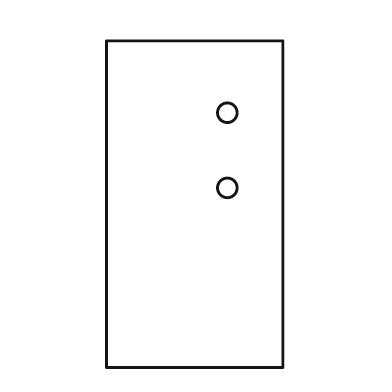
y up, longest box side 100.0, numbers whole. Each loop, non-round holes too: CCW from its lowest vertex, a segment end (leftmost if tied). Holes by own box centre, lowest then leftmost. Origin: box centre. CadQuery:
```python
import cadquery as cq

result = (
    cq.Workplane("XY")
    .moveTo(-27.0, -50.0)
    .lineTo(27.0, -50.0)
    .lineTo(27.0, 50.0)
    .lineTo(-27.0, 50.0)
    .close()
    .moveTo(10.0, 5.0)
    .circle(3.0)
    .moveTo(10.0, 28.0)
    .circle(3.0)
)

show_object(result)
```